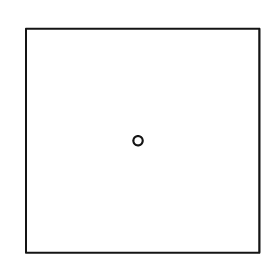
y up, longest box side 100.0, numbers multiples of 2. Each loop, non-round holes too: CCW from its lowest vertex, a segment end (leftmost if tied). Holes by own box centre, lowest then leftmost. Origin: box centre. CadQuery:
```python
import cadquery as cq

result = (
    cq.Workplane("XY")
    .moveTo(-50.0, -48.0)
    .lineTo(50.0, -48.0)
    .lineTo(50.0, 48.0)
    .lineTo(-50.0, 48.0)
    .close()
    .moveTo(-2.0, 0.0)
    .circle(2.0)
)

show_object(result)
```